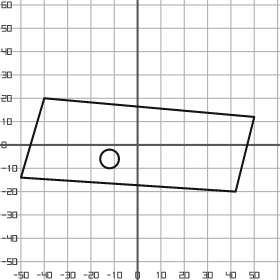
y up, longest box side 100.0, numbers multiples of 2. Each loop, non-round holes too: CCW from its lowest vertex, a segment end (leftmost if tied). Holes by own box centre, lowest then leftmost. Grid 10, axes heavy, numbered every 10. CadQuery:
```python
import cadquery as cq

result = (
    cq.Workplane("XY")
    .moveTo(42.0, -20.0)
    .lineTo(50.0, 12.0)
    .lineTo(-40.0, 20.0)
    .lineTo(-50.0, -14.0)
    .close()
    .moveTo(-12.0, -6.0)
    .circle(4.0)
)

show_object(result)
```